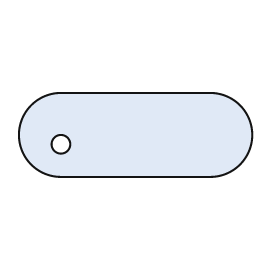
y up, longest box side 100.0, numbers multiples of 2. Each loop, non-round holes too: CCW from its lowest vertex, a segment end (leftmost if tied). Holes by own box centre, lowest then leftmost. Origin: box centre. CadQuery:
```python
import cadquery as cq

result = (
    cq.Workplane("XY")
    .moveTo(-32.0, -18.0)
    .lineTo(32.0, -18.0)
    .threePointArc((50.0, 0.0), (32.0, 18.0))
    .lineTo(-32.0, 18.0)
    .threePointArc((-50.0, 0.0), (-32.0, -18.0))
    .close()
    .moveTo(-32.0, -4.0)
    .circle(4.0)
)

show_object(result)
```